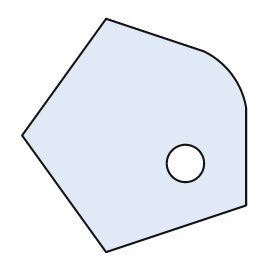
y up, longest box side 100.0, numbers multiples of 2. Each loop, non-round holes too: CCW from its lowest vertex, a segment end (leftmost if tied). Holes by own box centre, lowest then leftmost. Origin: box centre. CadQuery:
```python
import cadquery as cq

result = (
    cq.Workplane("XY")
    .moveTo(-12.0, -50.0)
    .lineTo(48.0, -30.0)
    .lineTo(48.0, 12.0)
    .threePointArc((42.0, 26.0), (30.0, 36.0))
    .lineTo(-12.0, 50.0)
    .lineTo(-48.0, 0.0)
    .close()
    .moveTo(22.0, -12.0)
    .circle(8.0)
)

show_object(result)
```